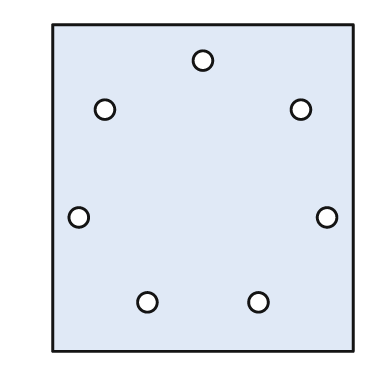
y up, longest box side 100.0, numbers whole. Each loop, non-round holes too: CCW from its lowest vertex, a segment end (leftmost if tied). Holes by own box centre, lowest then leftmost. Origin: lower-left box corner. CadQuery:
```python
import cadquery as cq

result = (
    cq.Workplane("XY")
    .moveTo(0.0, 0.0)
    .lineTo(92.0, 0.0)
    .lineTo(92.0, 100.0)
    .lineTo(0.0, 100.0)
    .close()
    .moveTo(29.0, 15.0)
    .circle(3.0)
    .moveTo(63.0, 15.0)
    .circle(3.0)
    .moveTo(8.0, 41.0)
    .circle(3.0)
    .moveTo(84.0, 41.0)
    .circle(3.0)
    .moveTo(16.0, 74.0)
    .circle(3.0)
    .moveTo(76.0, 74.0)
    .circle(3.0)
    .moveTo(46.0, 89.0)
    .circle(3.0)
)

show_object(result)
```